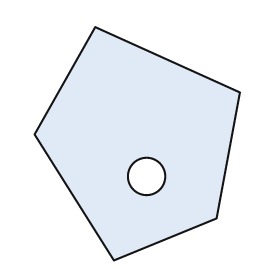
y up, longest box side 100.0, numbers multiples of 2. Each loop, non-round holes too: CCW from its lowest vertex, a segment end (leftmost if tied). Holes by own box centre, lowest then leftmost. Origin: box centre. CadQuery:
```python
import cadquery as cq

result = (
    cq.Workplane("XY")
    .moveTo(-10.0, -50.0)
    .lineTo(34.0, -32.0)
    .lineTo(44.0, 22.0)
    .lineTo(-18.0, 50.0)
    .lineTo(-44.0, 4.0)
    .close()
    .moveTo(4.0, -14.0)
    .circle(8.0)
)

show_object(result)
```